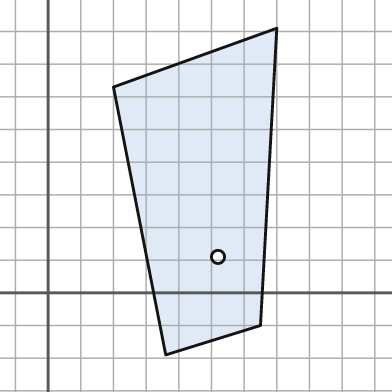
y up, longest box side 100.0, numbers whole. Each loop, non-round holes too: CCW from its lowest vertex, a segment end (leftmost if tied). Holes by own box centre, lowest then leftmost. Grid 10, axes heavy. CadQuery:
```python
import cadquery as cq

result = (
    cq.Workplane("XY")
    .moveTo(36.0, -19.0)
    .lineTo(65.0, -10.0)
    .lineTo(70.0, 81.0)
    .lineTo(20.0, 63.0)
    .close()
    .moveTo(52.0, 11.0)
    .circle(2.0)
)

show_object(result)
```